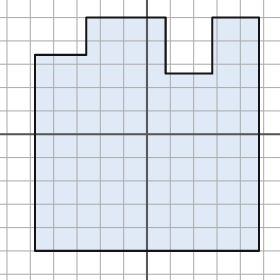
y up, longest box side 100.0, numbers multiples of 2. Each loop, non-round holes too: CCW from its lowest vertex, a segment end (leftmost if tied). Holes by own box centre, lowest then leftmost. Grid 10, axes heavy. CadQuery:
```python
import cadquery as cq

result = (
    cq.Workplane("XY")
    .moveTo(-48.0, -50.0)
    .lineTo(48.0, -50.0)
    .lineTo(48.0, 50.0)
    .lineTo(28.0, 50.0)
    .lineTo(28.0, 26.0)
    .lineTo(8.0, 26.0)
    .lineTo(8.0, 50.0)
    .lineTo(-26.0, 50.0)
    .lineTo(-26.0, 34.0)
    .lineTo(-48.0, 34.0)
    .close()
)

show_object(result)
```